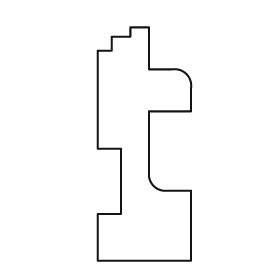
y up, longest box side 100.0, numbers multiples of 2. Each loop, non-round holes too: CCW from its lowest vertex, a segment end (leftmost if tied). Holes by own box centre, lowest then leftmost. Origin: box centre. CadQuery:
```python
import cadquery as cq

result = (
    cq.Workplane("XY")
    .moveTo(-20.0, -50.0)
    .lineTo(20.0, -50.0)
    .lineTo(20.0, -20.0)
    .lineTo(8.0, -20.0)
    .threePointArc((4.0, -18.0), (2.0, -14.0))
    .lineTo(2.0, 14.0)
    .lineTo(20.0, 14.0)
    .lineTo(20.0, 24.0)
    .threePointArc((18.0, 30.0), (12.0, 32.0))
    .lineTo(2.0, 32.0)
    .lineTo(2.0, 50.0)
    .lineTo(-6.0, 50.0)
    .lineTo(-6.0, 46.0)
    .lineTo(-14.0, 46.0)
    .lineTo(-14.0, 40.0)
    .lineTo(-20.0, 40.0)
    .lineTo(-20.0, -2.0)
    .lineTo(-10.0, -2.0)
    .lineTo(-10.0, -30.0)
    .lineTo(-20.0, -30.0)
    .close()
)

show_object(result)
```